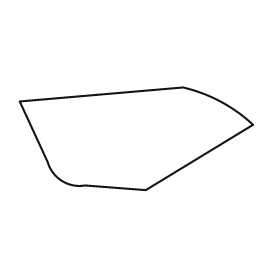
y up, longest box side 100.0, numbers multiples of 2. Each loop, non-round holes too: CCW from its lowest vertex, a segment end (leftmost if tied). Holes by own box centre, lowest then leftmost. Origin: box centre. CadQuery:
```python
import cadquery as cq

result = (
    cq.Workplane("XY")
    .moveTo(4.0, -22.0)
    .lineTo(50.0, 6.0)
    .threePointArc((36.0, 16.0), (20.0, 22.0))
    .lineTo(-50.0, 16.0)
    .lineTo(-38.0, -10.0)
    .threePointArc((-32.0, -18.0), (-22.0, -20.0))
    .close()
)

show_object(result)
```